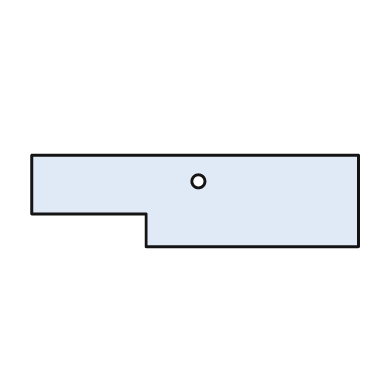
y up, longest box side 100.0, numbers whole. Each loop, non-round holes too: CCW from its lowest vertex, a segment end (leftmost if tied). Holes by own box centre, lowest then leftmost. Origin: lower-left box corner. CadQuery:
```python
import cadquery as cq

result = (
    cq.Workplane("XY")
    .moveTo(35.0, 0.0)
    .lineTo(100.0, 0.0)
    .lineTo(100.0, 28.0)
    .lineTo(0.0, 28.0)
    .lineTo(0.0, 10.0)
    .lineTo(35.0, 10.0)
    .close()
    .moveTo(51.0, 20.0)
    .circle(2.0)
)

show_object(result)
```